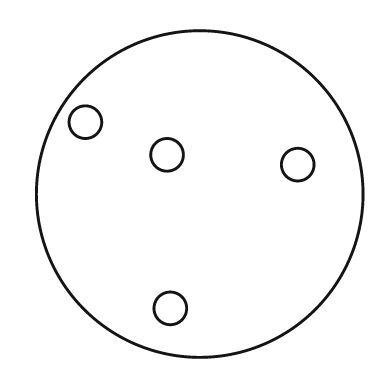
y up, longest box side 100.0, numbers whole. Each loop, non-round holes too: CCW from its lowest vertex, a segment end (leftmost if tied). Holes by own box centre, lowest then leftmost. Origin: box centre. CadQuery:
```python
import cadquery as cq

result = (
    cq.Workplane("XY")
    .moveTo(0.0, 0.0)
    .circle(50.0)
    .moveTo(-9.0, -35.0)
    .circle(5.0)
    .moveTo(30.0, 9.0)
    .circle(5.0)
    .moveTo(-10.0, 12.0)
    .circle(5.0)
    .moveTo(-35.0, 22.0)
    .circle(5.0)
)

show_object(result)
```